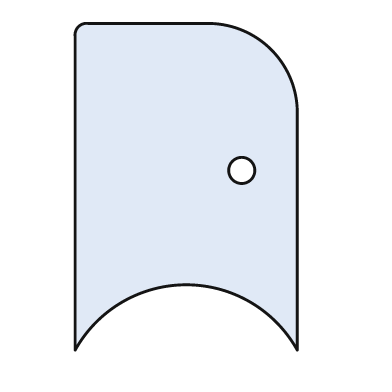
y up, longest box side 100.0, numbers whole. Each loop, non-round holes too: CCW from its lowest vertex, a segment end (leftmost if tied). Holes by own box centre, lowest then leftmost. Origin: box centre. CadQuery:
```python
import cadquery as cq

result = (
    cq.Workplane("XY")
    .moveTo(-34.0, -50.0)
    .threePointArc((0.0, -30.0), (34.0, -50.0))
    .lineTo(34.0, 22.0)
    .threePointArc((26.0, 42.0), (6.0, 50.0))
    .lineTo(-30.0, 50.0)
    .threePointArc((-33.0, 49.0), (-34.0, 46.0))
    .close()
    .moveTo(17.0, 5.0)
    .circle(4.0)
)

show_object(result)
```